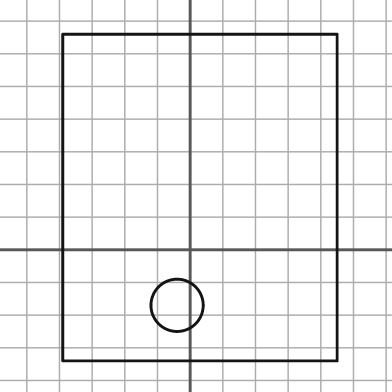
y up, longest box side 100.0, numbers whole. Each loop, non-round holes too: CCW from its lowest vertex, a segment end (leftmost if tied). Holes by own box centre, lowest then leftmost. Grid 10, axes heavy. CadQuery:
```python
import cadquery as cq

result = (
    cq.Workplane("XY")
    .moveTo(-39.0, -34.0)
    .lineTo(45.0, -34.0)
    .lineTo(45.0, 66.0)
    .lineTo(-39.0, 66.0)
    .close()
    .moveTo(-4.0, -17.0)
    .circle(8.0)
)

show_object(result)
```